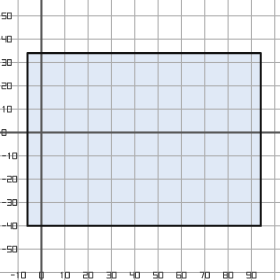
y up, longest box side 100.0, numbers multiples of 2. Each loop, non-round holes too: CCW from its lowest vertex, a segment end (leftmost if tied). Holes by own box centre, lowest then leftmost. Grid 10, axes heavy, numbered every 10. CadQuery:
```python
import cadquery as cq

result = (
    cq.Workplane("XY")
    .moveTo(-6.0, -40.0)
    .lineTo(94.0, -40.0)
    .lineTo(94.0, 34.0)
    .lineTo(-6.0, 34.0)
    .close()
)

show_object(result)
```